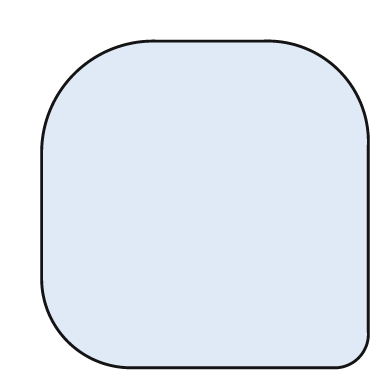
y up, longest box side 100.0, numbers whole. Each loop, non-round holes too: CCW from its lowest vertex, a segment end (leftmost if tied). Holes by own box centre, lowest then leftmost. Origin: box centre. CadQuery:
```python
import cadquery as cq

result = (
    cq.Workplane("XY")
    .moveTo(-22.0, -50.0)
    .lineTo(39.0, -50.0)
    .threePointArc((47.0, -47.0), (50.0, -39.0))
    .lineTo(50.0, 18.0)
    .threePointArc((41.0, 41.0), (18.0, 50.0))
    .lineTo(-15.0, 50.0)
    .threePointArc((-40.0, 40.0), (-50.0, 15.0))
    .lineTo(-50.0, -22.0)
    .threePointArc((-42.0, -42.0), (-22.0, -50.0))
    .close()
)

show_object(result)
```